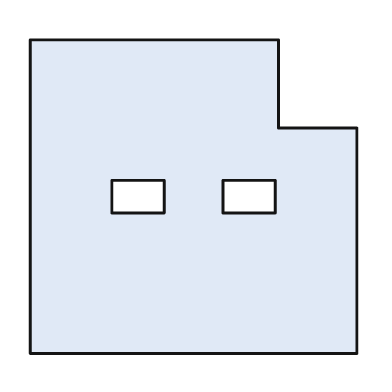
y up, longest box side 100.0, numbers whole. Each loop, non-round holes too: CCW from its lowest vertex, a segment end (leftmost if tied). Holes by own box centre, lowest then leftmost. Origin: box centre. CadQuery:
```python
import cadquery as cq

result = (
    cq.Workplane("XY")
    .moveTo(-50.0, -48.0)
    .lineTo(50.0, -48.0)
    .lineTo(50.0, 21.0)
    .lineTo(26.0, 21.0)
    .lineTo(26.0, 48.0)
    .lineTo(-50.0, 48.0)
    .close()
    .moveTo(-25.0, -5.0)
    .lineTo(-9.0, -5.0)
    .lineTo(-9.0, 5.0)
    .lineTo(-25.0, 5.0)
    .close()
    .moveTo(9.0, -5.0)
    .lineTo(25.0, -5.0)
    .lineTo(25.0, 5.0)
    .lineTo(9.0, 5.0)
    .close()
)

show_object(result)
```